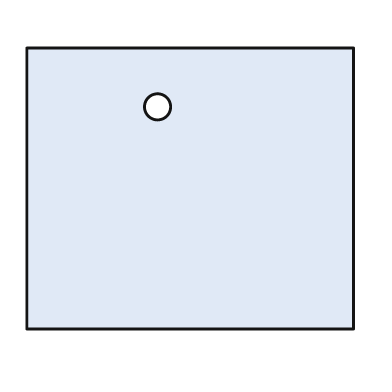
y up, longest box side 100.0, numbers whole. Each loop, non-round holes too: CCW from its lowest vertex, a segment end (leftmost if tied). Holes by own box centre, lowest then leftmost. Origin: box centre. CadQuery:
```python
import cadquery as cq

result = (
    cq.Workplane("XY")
    .moveTo(-50.0, -43.0)
    .lineTo(50.0, -43.0)
    .lineTo(50.0, 43.0)
    .lineTo(-50.0, 43.0)
    .close()
    .moveTo(-10.0, 25.0)
    .circle(4.0)
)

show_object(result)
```